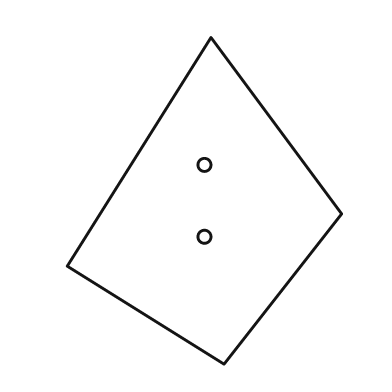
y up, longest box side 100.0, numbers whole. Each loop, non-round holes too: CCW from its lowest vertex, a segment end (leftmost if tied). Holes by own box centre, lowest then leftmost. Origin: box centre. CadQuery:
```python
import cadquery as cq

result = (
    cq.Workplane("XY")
    .moveTo(6.0, -50.0)
    .lineTo(42.0, -4.0)
    .lineTo(2.0, 50.0)
    .lineTo(-42.0, -20.0)
    .close()
    .moveTo(0.0, -11.0)
    .circle(2.0)
    .moveTo(0.0, 11.0)
    .circle(2.0)
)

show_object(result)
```